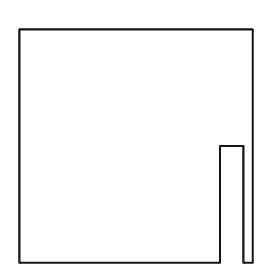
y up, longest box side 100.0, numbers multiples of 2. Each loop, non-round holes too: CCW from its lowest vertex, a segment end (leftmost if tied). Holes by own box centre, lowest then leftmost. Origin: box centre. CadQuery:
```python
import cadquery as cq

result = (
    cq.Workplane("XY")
    .moveTo(-50.0, -50.0)
    .lineTo(36.0, -50.0)
    .lineTo(36.0, 0.0)
    .lineTo(46.0, 0.0)
    .lineTo(46.0, -50.0)
    .lineTo(50.0, -50.0)
    .lineTo(50.0, 50.0)
    .lineTo(-50.0, 50.0)
    .close()
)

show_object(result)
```